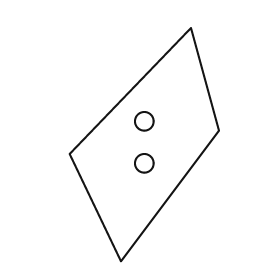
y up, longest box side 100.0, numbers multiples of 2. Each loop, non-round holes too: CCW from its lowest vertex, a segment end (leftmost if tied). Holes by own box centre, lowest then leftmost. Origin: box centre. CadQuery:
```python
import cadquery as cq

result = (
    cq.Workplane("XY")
    .moveTo(-10.0, -50.0)
    .lineTo(32.0, 6.0)
    .lineTo(20.0, 50.0)
    .lineTo(-32.0, -4.0)
    .close()
    .moveTo(0.0, -8.0)
    .circle(4.0)
    .moveTo(0.0, 10.0)
    .circle(4.0)
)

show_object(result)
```